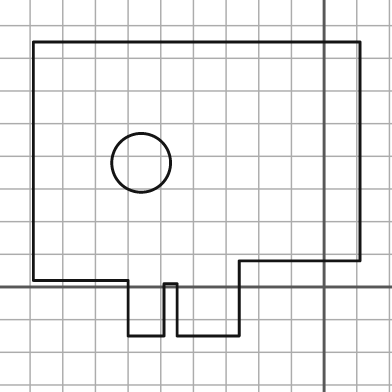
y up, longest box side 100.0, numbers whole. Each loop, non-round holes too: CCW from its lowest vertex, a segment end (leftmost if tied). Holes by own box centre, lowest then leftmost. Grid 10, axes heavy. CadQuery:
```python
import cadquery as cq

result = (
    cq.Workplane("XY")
    .moveTo(-60.0, -15.0)
    .lineTo(-49.0, -15.0)
    .lineTo(-49.0, 1.0)
    .lineTo(-45.0, 1.0)
    .lineTo(-45.0, -15.0)
    .lineTo(-26.0, -15.0)
    .lineTo(-26.0, 8.0)
    .lineTo(11.0, 8.0)
    .lineTo(11.0, 75.0)
    .lineTo(-89.0, 75.0)
    .lineTo(-89.0, 2.0)
    .lineTo(-60.0, 2.0)
    .close()
    .moveTo(-56.0, 38.0)
    .circle(9.0)
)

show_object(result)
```